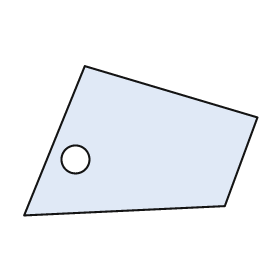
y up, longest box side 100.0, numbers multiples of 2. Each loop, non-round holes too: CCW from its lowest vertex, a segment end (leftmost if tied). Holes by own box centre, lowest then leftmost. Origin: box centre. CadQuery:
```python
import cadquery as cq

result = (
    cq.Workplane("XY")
    .moveTo(-50.0, -32.0)
    .lineTo(36.0, -28.0)
    .lineTo(50.0, 10.0)
    .lineTo(-24.0, 32.0)
    .close()
    .moveTo(-28.0, -8.0)
    .circle(6.0)
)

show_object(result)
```